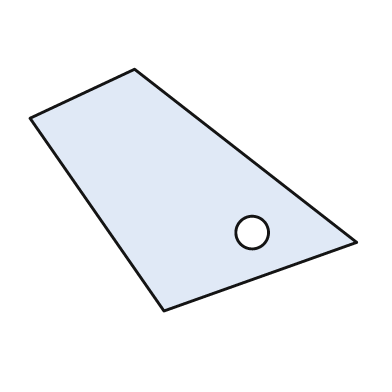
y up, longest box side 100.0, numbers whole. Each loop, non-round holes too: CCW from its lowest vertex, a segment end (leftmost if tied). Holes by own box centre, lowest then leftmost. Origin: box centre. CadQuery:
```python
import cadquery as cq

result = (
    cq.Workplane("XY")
    .moveTo(-9.0, -37.0)
    .lineTo(50.0, -16.0)
    .lineTo(-18.0, 37.0)
    .lineTo(-50.0, 22.0)
    .close()
    .moveTo(18.0, -13.0)
    .circle(5.0)
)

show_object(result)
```